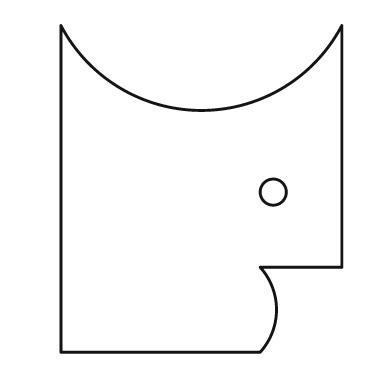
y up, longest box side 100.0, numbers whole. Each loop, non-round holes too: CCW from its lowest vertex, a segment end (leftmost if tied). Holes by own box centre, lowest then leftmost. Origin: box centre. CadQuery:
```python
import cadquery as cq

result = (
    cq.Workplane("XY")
    .moveTo(-43.0, -50.0)
    .lineTo(18.0, -50.0)
    .threePointArc((23.0, -37.0), (18.0, -24.0))
    .lineTo(43.0, -24.0)
    .lineTo(43.0, 50.0)
    .threePointArc((0.0, 24.0), (-43.0, 50.0))
    .close()
    .moveTo(22.0, -1.0)
    .circle(4.0)
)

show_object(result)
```